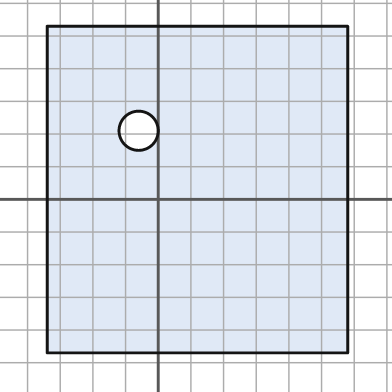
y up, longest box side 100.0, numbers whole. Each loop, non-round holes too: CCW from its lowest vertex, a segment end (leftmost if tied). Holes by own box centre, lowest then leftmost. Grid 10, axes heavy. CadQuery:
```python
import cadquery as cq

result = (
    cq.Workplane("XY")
    .moveTo(-34.0, -47.0)
    .lineTo(58.0, -47.0)
    .lineTo(58.0, 53.0)
    .lineTo(-34.0, 53.0)
    .close()
    .moveTo(-6.0, 21.0)
    .circle(6.0)
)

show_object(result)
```